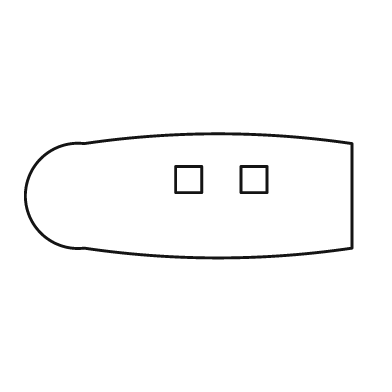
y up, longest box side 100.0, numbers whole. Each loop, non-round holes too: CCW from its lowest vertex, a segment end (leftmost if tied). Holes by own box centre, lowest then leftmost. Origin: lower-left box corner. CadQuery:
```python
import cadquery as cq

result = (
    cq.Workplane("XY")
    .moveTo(18.0, 3.0)
    .threePointArc((59.0, 0.0), (100.0, 3.0))
    .lineTo(100.0, 35.0)
    .threePointArc((59.0, 38.0), (18.0, 35.0))
    .threePointArc((0.0, 19.0), (18.0, 3.0))
    .close()
    .moveTo(46.0, 20.0)
    .lineTo(54.0, 20.0)
    .lineTo(54.0, 28.0)
    .lineTo(46.0, 28.0)
    .close()
    .moveTo(66.0, 20.0)
    .lineTo(74.0, 20.0)
    .lineTo(74.0, 28.0)
    .lineTo(66.0, 28.0)
    .close()
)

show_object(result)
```